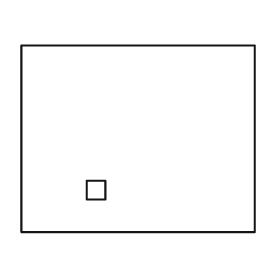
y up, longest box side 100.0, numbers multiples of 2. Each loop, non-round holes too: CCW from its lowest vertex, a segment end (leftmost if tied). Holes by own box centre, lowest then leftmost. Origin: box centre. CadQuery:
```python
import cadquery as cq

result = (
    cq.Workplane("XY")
    .moveTo(-50.0, -40.0)
    .lineTo(50.0, -40.0)
    .lineTo(50.0, 40.0)
    .lineTo(-50.0, 40.0)
    .close()
    .moveTo(-22.0, -26.0)
    .lineTo(-14.0, -26.0)
    .lineTo(-14.0, -18.0)
    .lineTo(-22.0, -18.0)
    .close()
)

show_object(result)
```